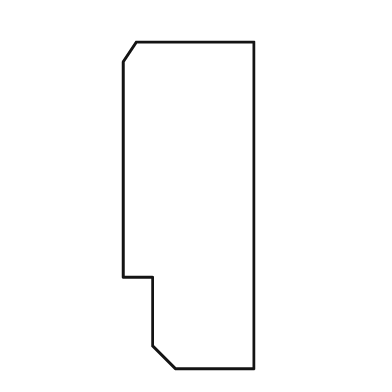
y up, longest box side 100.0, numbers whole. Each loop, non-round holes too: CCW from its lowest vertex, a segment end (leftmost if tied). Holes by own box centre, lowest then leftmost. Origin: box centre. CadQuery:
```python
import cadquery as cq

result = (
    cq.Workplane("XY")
    .moveTo(-4.0, -50.0)
    .lineTo(20.0, -50.0)
    .lineTo(20.0, 50.0)
    .lineTo(-16.0, 50.0)
    .lineTo(-20.0, 44.0)
    .lineTo(-20.0, -22.0)
    .lineTo(-11.0, -22.0)
    .lineTo(-11.0, -43.0)
    .close()
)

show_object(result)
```